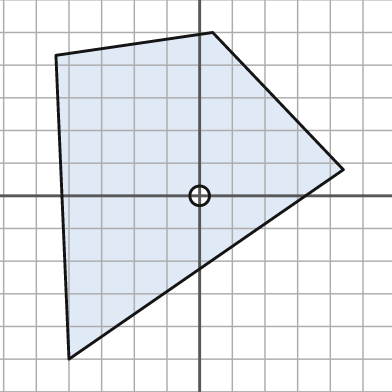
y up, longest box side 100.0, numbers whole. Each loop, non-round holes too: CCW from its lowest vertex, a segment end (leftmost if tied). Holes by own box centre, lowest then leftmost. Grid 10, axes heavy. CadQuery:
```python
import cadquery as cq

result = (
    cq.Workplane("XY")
    .moveTo(-40.0, -50.0)
    .lineTo(44.0, 8.0)
    .lineTo(4.0, 50.0)
    .lineTo(-44.0, 43.0)
    .close()
    .moveTo(0.0, 0.0)
    .circle(3.0)
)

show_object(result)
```